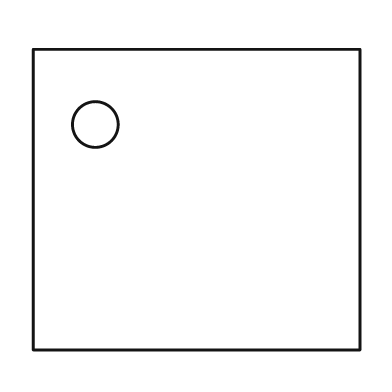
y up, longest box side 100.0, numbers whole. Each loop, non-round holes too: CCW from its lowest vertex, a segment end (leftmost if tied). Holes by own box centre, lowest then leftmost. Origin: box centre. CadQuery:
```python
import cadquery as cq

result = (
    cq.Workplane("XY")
    .moveTo(-50.0, -46.0)
    .lineTo(50.0, -46.0)
    .lineTo(50.0, 46.0)
    .lineTo(-50.0, 46.0)
    .close()
    .moveTo(-31.0, 23.0)
    .circle(7.0)
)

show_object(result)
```